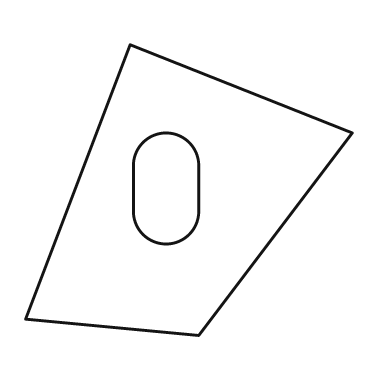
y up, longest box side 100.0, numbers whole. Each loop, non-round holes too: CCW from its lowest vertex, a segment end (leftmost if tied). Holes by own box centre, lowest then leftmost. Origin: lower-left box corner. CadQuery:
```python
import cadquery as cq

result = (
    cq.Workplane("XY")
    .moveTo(53.0, 0.0)
    .lineTo(100.0, 62.0)
    .lineTo(32.0, 89.0)
    .lineTo(0.0, 5.0)
    .close()
    .moveTo(33.0, 38.0)
    .threePointArc((43.0, 28.0), (53.0, 38.0))
    .lineTo(53.0, 52.0)
    .threePointArc((43.0, 62.0), (33.0, 52.0))
    .close()
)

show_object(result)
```